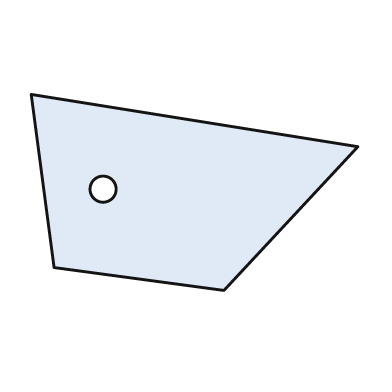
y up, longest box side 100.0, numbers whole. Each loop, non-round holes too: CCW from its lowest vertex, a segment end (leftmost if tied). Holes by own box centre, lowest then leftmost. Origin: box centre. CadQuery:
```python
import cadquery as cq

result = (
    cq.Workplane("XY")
    .moveTo(9.0, -30.0)
    .lineTo(50.0, 14.0)
    .lineTo(-50.0, 30.0)
    .lineTo(-43.0, -23.0)
    .close()
    .moveTo(-28.0, 1.0)
    .circle(4.0)
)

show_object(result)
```